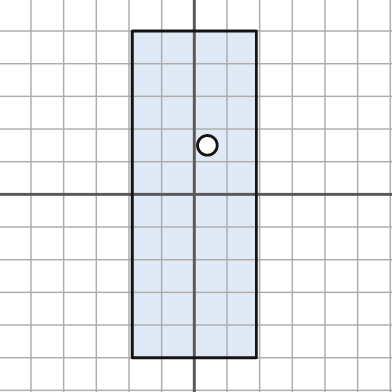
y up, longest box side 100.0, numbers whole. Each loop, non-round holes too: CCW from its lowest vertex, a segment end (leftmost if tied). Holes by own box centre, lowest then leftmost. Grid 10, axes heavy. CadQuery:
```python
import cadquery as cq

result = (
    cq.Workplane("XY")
    .moveTo(-19.0, -50.0)
    .lineTo(19.0, -50.0)
    .lineTo(19.0, 50.0)
    .lineTo(-19.0, 50.0)
    .close()
    .moveTo(4.0, 15.0)
    .circle(3.0)
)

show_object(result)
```